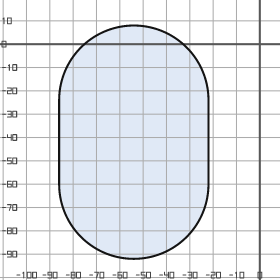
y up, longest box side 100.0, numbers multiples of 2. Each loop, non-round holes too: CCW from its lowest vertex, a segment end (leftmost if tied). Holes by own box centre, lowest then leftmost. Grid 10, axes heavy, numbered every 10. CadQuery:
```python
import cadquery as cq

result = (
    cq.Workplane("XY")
    .moveTo(-86.0, -60.0)
    .threePointArc((-54.0, -92.0), (-22.0, -60.0))
    .lineTo(-22.0, -24.0)
    .threePointArc((-54.0, 8.0), (-86.0, -24.0))
    .close()
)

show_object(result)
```